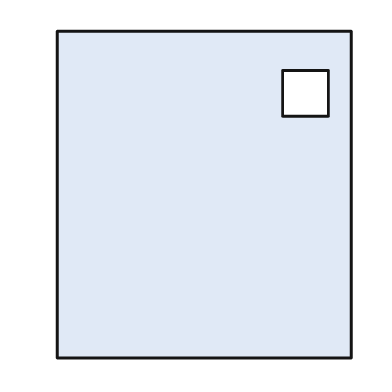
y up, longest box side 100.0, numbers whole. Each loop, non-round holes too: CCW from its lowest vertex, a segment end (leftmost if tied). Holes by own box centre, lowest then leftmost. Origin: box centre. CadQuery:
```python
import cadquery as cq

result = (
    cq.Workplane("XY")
    .moveTo(-45.0, -50.0)
    .lineTo(45.0, -50.0)
    .lineTo(45.0, 50.0)
    .lineTo(-45.0, 50.0)
    .close()
    .moveTo(24.0, 24.0)
    .lineTo(38.0, 24.0)
    .lineTo(38.0, 38.0)
    .lineTo(24.0, 38.0)
    .close()
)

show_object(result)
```